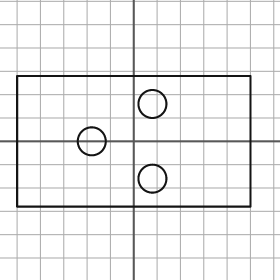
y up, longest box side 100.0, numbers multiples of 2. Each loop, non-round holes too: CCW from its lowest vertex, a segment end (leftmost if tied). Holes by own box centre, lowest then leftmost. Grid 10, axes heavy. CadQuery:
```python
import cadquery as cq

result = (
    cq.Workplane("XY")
    .moveTo(-50.0, -28.0)
    .lineTo(50.0, -28.0)
    .lineTo(50.0, 28.0)
    .lineTo(-50.0, 28.0)
    .close()
    .moveTo(8.0, -16.0)
    .circle(6.0)
    .moveTo(-18.0, 0.0)
    .circle(6.0)
    .moveTo(8.0, 16.0)
    .circle(6.0)
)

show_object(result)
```